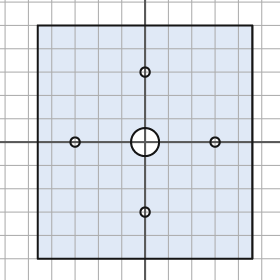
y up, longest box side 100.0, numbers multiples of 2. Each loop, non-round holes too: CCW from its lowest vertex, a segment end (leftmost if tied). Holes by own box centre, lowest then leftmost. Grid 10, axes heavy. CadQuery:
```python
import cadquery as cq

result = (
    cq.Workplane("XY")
    .moveTo(-46.0, -50.0)
    .lineTo(46.0, -50.0)
    .lineTo(46.0, 50.0)
    .lineTo(-46.0, 50.0)
    .close()
    .moveTo(0.0, -30.0)
    .circle(2.0)
    .moveTo(-30.0, 0.0)
    .circle(2.0)
    .moveTo(0.0, 0.0)
    .circle(6.0)
    .moveTo(30.0, 0.0)
    .circle(2.0)
    .moveTo(0.0, 30.0)
    .circle(2.0)
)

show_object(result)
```